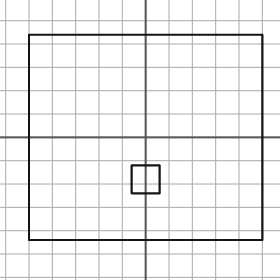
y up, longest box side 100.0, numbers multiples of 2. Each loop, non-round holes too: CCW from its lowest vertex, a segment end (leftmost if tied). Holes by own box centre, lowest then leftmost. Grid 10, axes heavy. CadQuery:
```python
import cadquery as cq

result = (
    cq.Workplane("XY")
    .moveTo(-50.0, -44.0)
    .lineTo(50.0, -44.0)
    .lineTo(50.0, 44.0)
    .lineTo(-50.0, 44.0)
    .close()
    .moveTo(-6.0, -24.0)
    .lineTo(6.0, -24.0)
    .lineTo(6.0, -12.0)
    .lineTo(-6.0, -12.0)
    .close()
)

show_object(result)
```